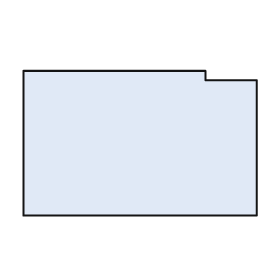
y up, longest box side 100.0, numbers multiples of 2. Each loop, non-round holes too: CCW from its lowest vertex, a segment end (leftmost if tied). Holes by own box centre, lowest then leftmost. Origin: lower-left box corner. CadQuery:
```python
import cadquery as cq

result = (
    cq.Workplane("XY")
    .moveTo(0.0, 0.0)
    .lineTo(100.0, 0.0)
    .lineTo(100.0, 58.0)
    .lineTo(78.0, 58.0)
    .lineTo(78.0, 62.0)
    .lineTo(0.0, 62.0)
    .close()
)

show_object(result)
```